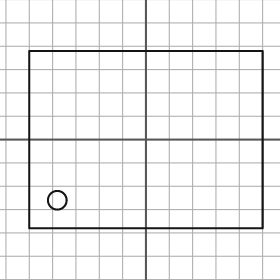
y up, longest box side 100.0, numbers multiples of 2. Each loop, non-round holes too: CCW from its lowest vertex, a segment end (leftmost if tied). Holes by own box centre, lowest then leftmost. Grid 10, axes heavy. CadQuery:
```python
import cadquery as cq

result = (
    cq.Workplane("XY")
    .moveTo(-50.0, -38.0)
    .lineTo(50.0, -38.0)
    .lineTo(50.0, 38.0)
    .lineTo(-50.0, 38.0)
    .close()
    .moveTo(-38.0, -26.0)
    .circle(4.0)
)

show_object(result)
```